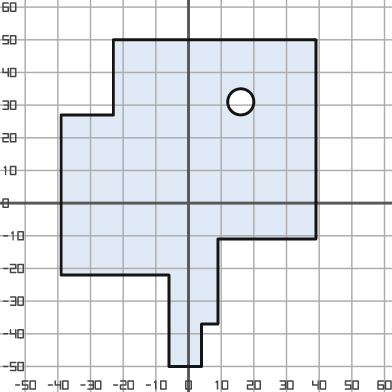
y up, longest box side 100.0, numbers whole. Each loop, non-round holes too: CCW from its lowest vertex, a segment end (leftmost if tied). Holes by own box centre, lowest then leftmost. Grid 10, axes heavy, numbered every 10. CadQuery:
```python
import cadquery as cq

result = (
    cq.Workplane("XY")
    .moveTo(-6.0, -50.0)
    .lineTo(4.0, -50.0)
    .lineTo(4.0, -37.0)
    .lineTo(9.0, -37.0)
    .lineTo(9.0, -11.0)
    .lineTo(39.0, -11.0)
    .lineTo(39.0, 50.0)
    .lineTo(-23.0, 50.0)
    .lineTo(-23.0, 27.0)
    .lineTo(-39.0, 27.0)
    .lineTo(-39.0, -22.0)
    .lineTo(-6.0, -22.0)
    .close()
    .moveTo(16.0, 31.0)
    .circle(4.0)
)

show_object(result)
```